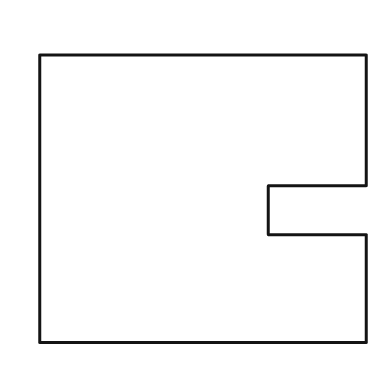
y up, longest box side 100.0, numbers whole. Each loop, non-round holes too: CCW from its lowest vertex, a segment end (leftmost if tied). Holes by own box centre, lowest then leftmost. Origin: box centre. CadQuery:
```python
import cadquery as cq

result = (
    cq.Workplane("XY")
    .moveTo(-50.0, -44.0)
    .lineTo(50.0, -44.0)
    .lineTo(50.0, -11.0)
    .lineTo(20.0, -11.0)
    .lineTo(20.0, 4.0)
    .lineTo(50.0, 4.0)
    .lineTo(50.0, 44.0)
    .lineTo(-50.0, 44.0)
    .close()
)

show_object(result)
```